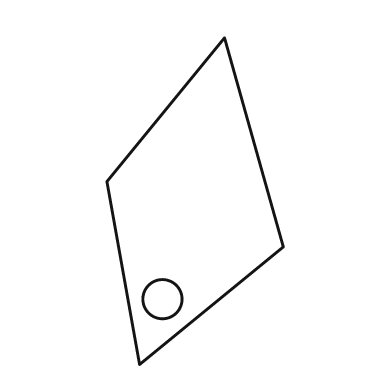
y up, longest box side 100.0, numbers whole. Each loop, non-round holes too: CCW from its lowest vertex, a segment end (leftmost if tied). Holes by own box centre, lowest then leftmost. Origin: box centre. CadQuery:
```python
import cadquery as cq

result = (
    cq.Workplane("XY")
    .moveTo(-17.0, -50.0)
    .lineTo(27.0, -14.0)
    .lineTo(9.0, 50.0)
    .lineTo(-27.0, 6.0)
    .close()
    .moveTo(-10.0, -30.0)
    .circle(6.0)
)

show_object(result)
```